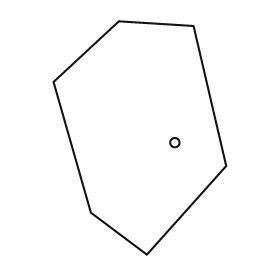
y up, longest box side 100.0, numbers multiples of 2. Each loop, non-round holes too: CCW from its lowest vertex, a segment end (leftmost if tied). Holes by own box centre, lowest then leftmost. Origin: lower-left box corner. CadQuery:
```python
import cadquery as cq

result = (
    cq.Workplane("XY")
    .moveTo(40.0, 0.0)
    .lineTo(74.0, 38.0)
    .lineTo(60.0, 98.0)
    .lineTo(28.0, 100.0)
    .lineTo(0.0, 74.0)
    .lineTo(16.0, 18.0)
    .close()
    .moveTo(52.0, 48.0)
    .circle(2.0)
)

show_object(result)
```